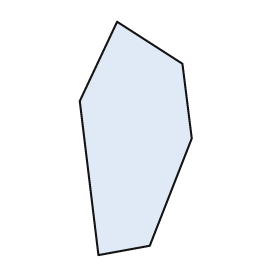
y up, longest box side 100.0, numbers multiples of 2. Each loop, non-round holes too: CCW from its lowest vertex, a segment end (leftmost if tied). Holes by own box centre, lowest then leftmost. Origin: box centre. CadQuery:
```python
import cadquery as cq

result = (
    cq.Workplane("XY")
    .moveTo(-16.0, -50.0)
    .lineTo(6.0, -46.0)
    .lineTo(24.0, 0.0)
    .lineTo(20.0, 32.0)
    .lineTo(-8.0, 50.0)
    .lineTo(-24.0, 16.0)
    .close()
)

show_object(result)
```